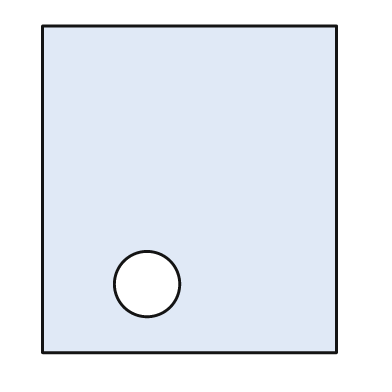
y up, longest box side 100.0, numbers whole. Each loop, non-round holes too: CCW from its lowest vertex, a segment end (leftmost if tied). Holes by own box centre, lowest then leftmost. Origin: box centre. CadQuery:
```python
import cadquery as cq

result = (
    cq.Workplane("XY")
    .moveTo(-45.0, -50.0)
    .lineTo(45.0, -50.0)
    .lineTo(45.0, 50.0)
    .lineTo(-45.0, 50.0)
    .close()
    .moveTo(-13.0, -29.0)
    .circle(10.0)
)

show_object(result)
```